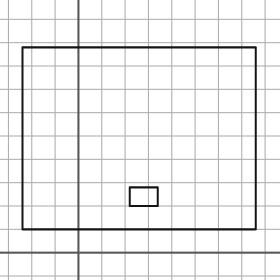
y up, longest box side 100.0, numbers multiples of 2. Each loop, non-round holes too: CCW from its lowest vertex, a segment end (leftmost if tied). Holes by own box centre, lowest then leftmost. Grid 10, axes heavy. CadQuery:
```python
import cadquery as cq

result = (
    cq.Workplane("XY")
    .moveTo(-24.0, 10.0)
    .lineTo(76.0, 10.0)
    .lineTo(76.0, 88.0)
    .lineTo(-24.0, 88.0)
    .close()
    .moveTo(22.0, 20.0)
    .lineTo(34.0, 20.0)
    .lineTo(34.0, 28.0)
    .lineTo(22.0, 28.0)
    .close()
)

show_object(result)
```